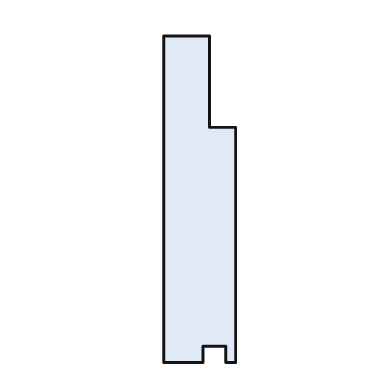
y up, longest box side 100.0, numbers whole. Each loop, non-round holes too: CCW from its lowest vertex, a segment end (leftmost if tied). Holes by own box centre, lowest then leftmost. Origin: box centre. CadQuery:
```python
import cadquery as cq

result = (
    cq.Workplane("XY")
    .moveTo(-11.0, -50.0)
    .lineTo(1.0, -50.0)
    .lineTo(1.0, -45.0)
    .lineTo(8.0, -45.0)
    .lineTo(8.0, -50.0)
    .lineTo(11.0, -50.0)
    .lineTo(11.0, 22.0)
    .lineTo(3.0, 22.0)
    .lineTo(3.0, 50.0)
    .lineTo(-11.0, 50.0)
    .close()
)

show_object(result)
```